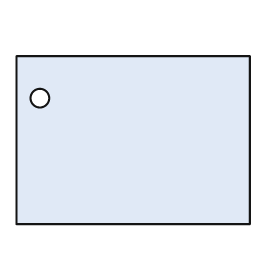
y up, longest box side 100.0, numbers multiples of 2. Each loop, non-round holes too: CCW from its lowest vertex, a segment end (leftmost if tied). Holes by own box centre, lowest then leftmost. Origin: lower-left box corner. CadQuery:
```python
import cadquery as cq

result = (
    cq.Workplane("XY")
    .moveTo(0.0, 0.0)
    .lineTo(100.0, 0.0)
    .lineTo(100.0, 72.0)
    .lineTo(0.0, 72.0)
    .close()
    .moveTo(10.0, 54.0)
    .circle(4.0)
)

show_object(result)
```